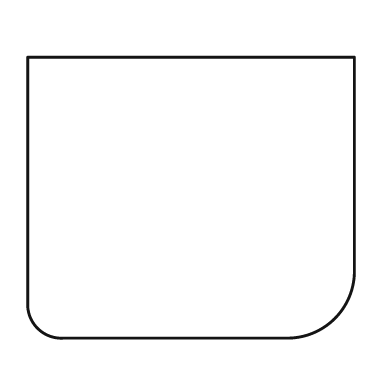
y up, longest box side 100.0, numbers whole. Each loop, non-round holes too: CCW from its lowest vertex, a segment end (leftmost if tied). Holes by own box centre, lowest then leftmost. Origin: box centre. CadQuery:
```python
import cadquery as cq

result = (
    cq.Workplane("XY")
    .moveTo(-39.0, -43.0)
    .lineTo(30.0, -43.0)
    .threePointArc((44.0, -37.0), (50.0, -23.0))
    .lineTo(50.0, 43.0)
    .lineTo(-50.0, 43.0)
    .lineTo(-50.0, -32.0)
    .threePointArc((-47.0, -40.0), (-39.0, -43.0))
    .close()
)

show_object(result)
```